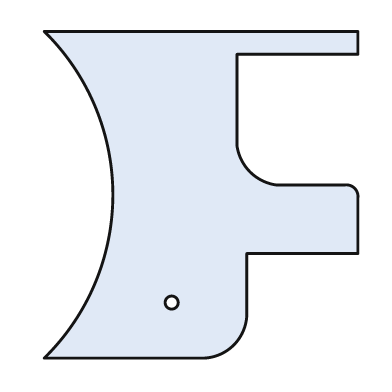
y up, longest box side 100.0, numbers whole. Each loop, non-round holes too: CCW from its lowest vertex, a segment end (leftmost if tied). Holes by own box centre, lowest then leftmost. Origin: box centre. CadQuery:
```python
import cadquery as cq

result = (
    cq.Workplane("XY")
    .moveTo(-48.0, -50.0)
    .lineTo(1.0, -50.0)
    .threePointArc((10.0, -46.0), (14.0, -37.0))
    .lineTo(14.0, -18.0)
    .lineTo(48.0, -18.0)
    .lineTo(48.0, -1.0)
    .threePointArc((47.0, 2.0), (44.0, 3.0))
    .lineTo(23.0, 3.0)
    .threePointArc((15.0, 7.0), (11.0, 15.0))
    .lineTo(11.0, 43.0)
    .lineTo(48.0, 43.0)
    .lineTo(48.0, 50.0)
    .lineTo(-48.0, 50.0)
    .threePointArc((-27.0, 0.0), (-48.0, -50.0))
    .close()
    .moveTo(-9.0, -33.0)
    .circle(2.0)
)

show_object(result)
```